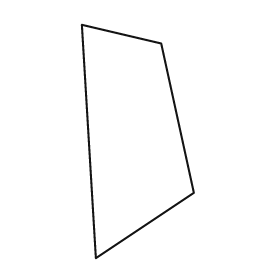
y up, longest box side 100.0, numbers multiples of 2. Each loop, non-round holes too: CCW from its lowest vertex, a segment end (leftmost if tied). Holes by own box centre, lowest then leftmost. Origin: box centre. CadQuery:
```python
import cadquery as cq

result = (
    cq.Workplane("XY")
    .moveTo(-18.0, -50.0)
    .lineTo(24.0, -22.0)
    .lineTo(10.0, 42.0)
    .lineTo(-24.0, 50.0)
    .close()
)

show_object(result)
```